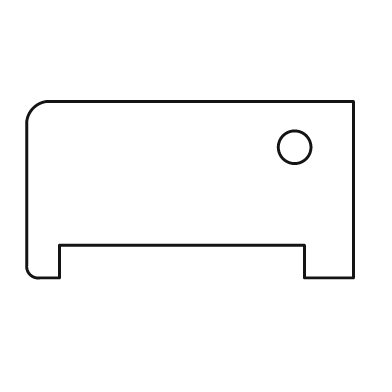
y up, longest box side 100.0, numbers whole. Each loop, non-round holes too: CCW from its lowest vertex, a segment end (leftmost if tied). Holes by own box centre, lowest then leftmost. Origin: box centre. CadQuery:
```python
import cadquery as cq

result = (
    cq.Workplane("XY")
    .moveTo(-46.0, -27.0)
    .lineTo(-40.0, -27.0)
    .lineTo(-40.0, -17.0)
    .lineTo(35.0, -17.0)
    .lineTo(35.0, -27.0)
    .lineTo(50.0, -27.0)
    .lineTo(50.0, 27.0)
    .lineTo(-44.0, 27.0)
    .threePointArc((-48.0, 25.0), (-50.0, 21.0))
    .lineTo(-50.0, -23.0)
    .threePointArc((-49.0, -26.0), (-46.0, -27.0))
    .close()
    .moveTo(32.0, 13.0)
    .circle(5.0)
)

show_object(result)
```